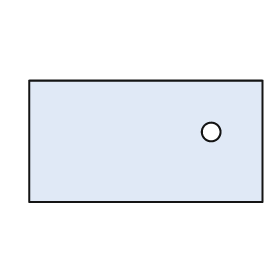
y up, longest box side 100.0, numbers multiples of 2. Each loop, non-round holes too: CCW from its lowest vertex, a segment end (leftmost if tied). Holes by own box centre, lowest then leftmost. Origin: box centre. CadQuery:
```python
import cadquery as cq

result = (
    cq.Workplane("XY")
    .moveTo(-50.0, -26.0)
    .lineTo(50.0, -26.0)
    .lineTo(50.0, 26.0)
    .lineTo(-50.0, 26.0)
    .close()
    .moveTo(28.0, 4.0)
    .circle(4.0)
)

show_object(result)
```